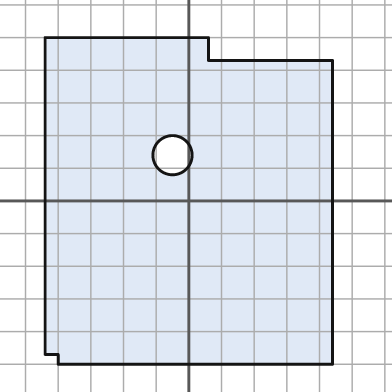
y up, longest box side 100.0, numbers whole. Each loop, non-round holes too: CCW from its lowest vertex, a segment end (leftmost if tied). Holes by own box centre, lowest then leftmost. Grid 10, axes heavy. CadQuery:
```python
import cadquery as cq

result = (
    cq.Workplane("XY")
    .moveTo(-40.0, -50.0)
    .lineTo(44.0, -50.0)
    .lineTo(44.0, 43.0)
    .lineTo(6.0, 43.0)
    .lineTo(6.0, 50.0)
    .lineTo(-44.0, 50.0)
    .lineTo(-44.0, -47.0)
    .lineTo(-40.0, -47.0)
    .close()
    .moveTo(-5.0, 14.0)
    .circle(6.0)
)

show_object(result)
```